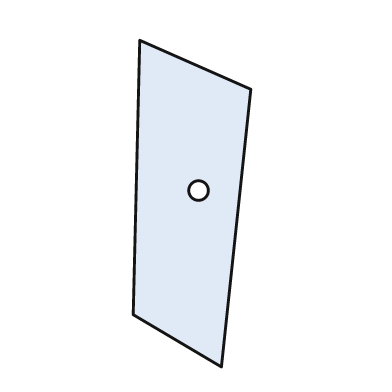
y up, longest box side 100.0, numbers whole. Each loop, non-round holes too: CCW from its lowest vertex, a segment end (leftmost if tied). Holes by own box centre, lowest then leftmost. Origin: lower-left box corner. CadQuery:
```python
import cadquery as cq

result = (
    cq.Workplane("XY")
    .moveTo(27.0, 0.0)
    .lineTo(36.0, 85.0)
    .lineTo(2.0, 100.0)
    .lineTo(0.0, 16.0)
    .close()
    .moveTo(20.0, 54.0)
    .circle(3.0)
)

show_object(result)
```